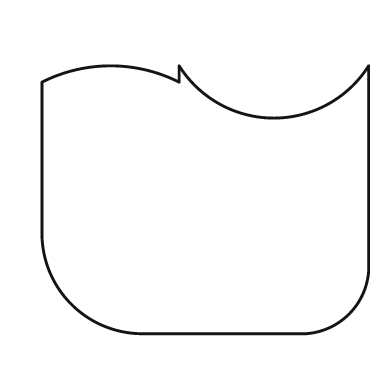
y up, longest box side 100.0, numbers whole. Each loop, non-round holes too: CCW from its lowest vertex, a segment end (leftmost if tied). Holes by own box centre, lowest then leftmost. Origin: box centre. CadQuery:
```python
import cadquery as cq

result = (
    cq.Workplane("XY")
    .moveTo(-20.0, -41.0)
    .lineTo(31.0, -41.0)
    .threePointArc((44.0, -35.0), (50.0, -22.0))
    .lineTo(50.0, 41.0)
    .threePointArc((21.0, 25.0), (-8.0, 41.0))
    .lineTo(-8.0, 36.0)
    .threePointArc((-29.0, 41.0), (-50.0, 36.0))
    .lineTo(-50.0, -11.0)
    .threePointArc((-41.0, -32.0), (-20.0, -41.0))
    .close()
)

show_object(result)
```